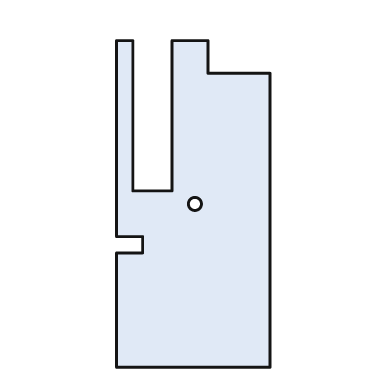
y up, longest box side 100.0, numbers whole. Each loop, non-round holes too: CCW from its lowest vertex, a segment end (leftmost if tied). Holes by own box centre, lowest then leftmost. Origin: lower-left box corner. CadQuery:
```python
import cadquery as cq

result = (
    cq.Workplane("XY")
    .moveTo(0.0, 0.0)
    .lineTo(47.0, 0.0)
    .lineTo(47.0, 90.0)
    .lineTo(28.0, 90.0)
    .lineTo(28.0, 100.0)
    .lineTo(17.0, 100.0)
    .lineTo(17.0, 54.0)
    .lineTo(5.0, 54.0)
    .lineTo(5.0, 100.0)
    .lineTo(0.0, 100.0)
    .lineTo(0.0, 40.0)
    .lineTo(8.0, 40.0)
    .lineTo(8.0, 35.0)
    .lineTo(0.0, 35.0)
    .close()
    .moveTo(24.0, 50.0)
    .circle(2.0)
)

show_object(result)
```